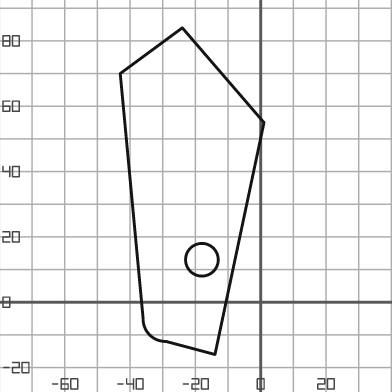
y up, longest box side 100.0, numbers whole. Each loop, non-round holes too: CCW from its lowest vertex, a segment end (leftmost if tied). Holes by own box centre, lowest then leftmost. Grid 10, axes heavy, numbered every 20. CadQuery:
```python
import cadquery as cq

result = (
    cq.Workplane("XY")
    .moveTo(-14.0, -16.0)
    .lineTo(1.0, 55.0)
    .lineTo(-24.0, 84.0)
    .lineTo(-43.0, 70.0)
    .lineTo(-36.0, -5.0)
    .threePointArc((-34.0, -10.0), (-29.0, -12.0))
    .close()
    .moveTo(-18.0, 13.0)
    .circle(5.0)
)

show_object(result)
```